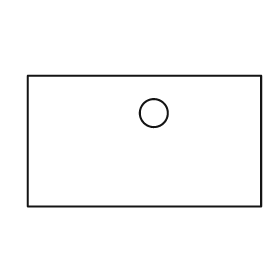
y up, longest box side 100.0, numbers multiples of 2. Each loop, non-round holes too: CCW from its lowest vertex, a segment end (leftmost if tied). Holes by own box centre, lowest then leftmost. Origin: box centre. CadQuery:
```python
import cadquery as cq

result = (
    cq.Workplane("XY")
    .moveTo(-50.0, -28.0)
    .lineTo(50.0, -28.0)
    .lineTo(50.0, 28.0)
    .lineTo(-50.0, 28.0)
    .close()
    .moveTo(4.0, 12.0)
    .circle(6.0)
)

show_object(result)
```